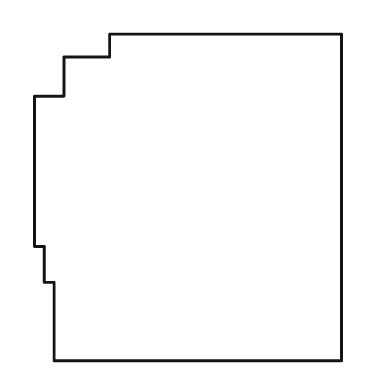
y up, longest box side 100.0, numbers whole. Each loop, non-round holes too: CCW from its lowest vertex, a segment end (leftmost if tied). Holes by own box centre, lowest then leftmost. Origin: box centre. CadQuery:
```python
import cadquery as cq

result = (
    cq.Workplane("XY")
    .moveTo(-41.0, -50.0)
    .lineTo(47.0, -50.0)
    .lineTo(47.0, 50.0)
    .lineTo(-24.0, 50.0)
    .lineTo(-24.0, 43.0)
    .lineTo(-38.0, 43.0)
    .lineTo(-38.0, 31.0)
    .lineTo(-47.0, 31.0)
    .lineTo(-47.0, -15.0)
    .lineTo(-44.0, -15.0)
    .lineTo(-44.0, -26.0)
    .lineTo(-41.0, -26.0)
    .close()
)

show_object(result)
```